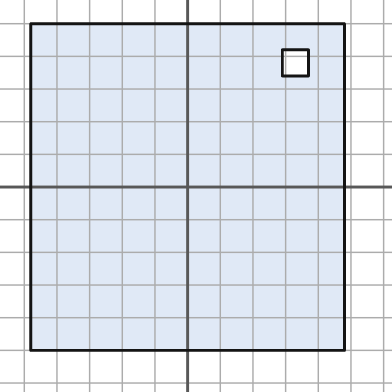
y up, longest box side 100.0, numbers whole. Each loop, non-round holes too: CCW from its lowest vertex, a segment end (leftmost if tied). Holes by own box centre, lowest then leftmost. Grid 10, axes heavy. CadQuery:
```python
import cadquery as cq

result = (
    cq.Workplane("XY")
    .moveTo(-48.0, -50.0)
    .lineTo(48.0, -50.0)
    .lineTo(48.0, 50.0)
    .lineTo(-48.0, 50.0)
    .close()
    .moveTo(29.0, 34.0)
    .lineTo(37.0, 34.0)
    .lineTo(37.0, 42.0)
    .lineTo(29.0, 42.0)
    .close()
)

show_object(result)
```